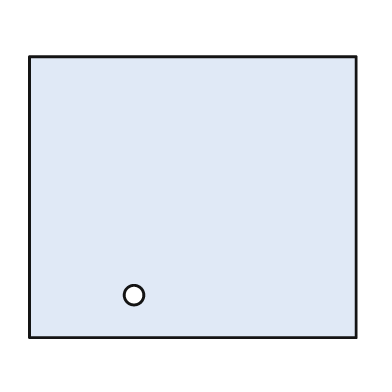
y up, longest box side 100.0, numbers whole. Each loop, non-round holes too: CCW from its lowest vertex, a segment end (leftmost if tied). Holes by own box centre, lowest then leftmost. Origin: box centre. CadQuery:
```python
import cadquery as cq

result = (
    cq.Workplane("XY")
    .moveTo(-50.0, -43.0)
    .lineTo(50.0, -43.0)
    .lineTo(50.0, 43.0)
    .lineTo(-50.0, 43.0)
    .close()
    .moveTo(-18.0, -30.0)
    .circle(3.0)
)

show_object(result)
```